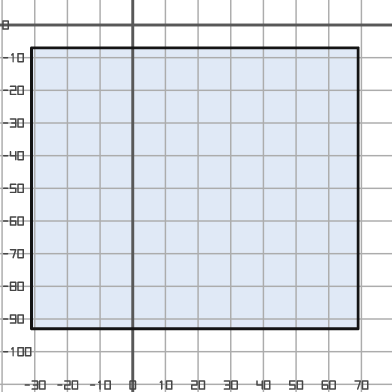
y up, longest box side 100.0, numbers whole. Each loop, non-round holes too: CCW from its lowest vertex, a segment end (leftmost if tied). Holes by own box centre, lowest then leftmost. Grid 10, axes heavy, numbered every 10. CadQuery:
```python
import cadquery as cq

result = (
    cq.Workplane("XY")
    .moveTo(-31.0, -93.0)
    .lineTo(69.0, -93.0)
    .lineTo(69.0, -7.0)
    .lineTo(-31.0, -7.0)
    .close()
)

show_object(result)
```